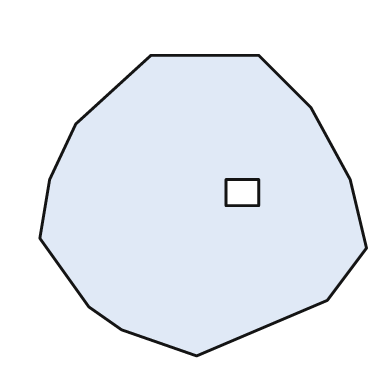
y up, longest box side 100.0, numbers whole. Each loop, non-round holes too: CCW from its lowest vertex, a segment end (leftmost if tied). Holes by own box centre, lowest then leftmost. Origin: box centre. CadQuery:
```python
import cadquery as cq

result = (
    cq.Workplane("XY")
    .moveTo(-2.0, -46.0)
    .lineTo(38.0, -29.0)
    .lineTo(50.0, -13.0)
    .lineTo(45.0, 8.0)
    .lineTo(33.0, 30.0)
    .lineTo(17.0, 46.0)
    .lineTo(-16.0, 46.0)
    .lineTo(-39.0, 25.0)
    .lineTo(-47.0, 8.0)
    .lineTo(-50.0, -10.0)
    .lineTo(-35.0, -31.0)
    .lineTo(-25.0, -38.0)
    .close()
    .moveTo(7.0, 0.0)
    .lineTo(17.0, 0.0)
    .lineTo(17.0, 8.0)
    .lineTo(7.0, 8.0)
    .close()
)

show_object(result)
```